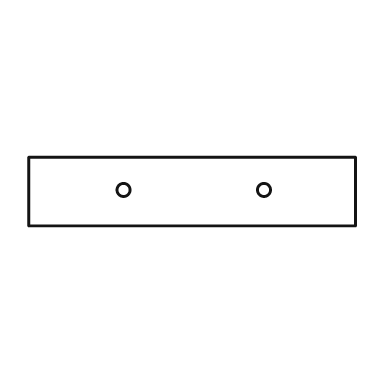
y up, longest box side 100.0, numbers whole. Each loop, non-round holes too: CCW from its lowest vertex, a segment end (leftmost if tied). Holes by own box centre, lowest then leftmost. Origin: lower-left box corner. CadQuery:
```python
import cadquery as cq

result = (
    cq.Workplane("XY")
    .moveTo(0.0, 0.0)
    .lineTo(100.0, 0.0)
    .lineTo(100.0, 21.0)
    .lineTo(0.0, 21.0)
    .close()
    .moveTo(29.0, 11.0)
    .circle(2.0)
    .moveTo(72.0, 11.0)
    .circle(2.0)
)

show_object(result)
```